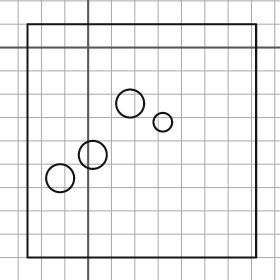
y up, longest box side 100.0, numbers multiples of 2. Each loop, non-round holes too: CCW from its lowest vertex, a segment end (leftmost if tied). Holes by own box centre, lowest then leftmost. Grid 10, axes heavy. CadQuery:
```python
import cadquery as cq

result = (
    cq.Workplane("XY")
    .moveTo(-26.0, -90.0)
    .lineTo(72.0, -90.0)
    .lineTo(72.0, 10.0)
    .lineTo(-26.0, 10.0)
    .close()
    .moveTo(-12.0, -56.0)
    .circle(6.0)
    .moveTo(2.0, -46.0)
    .circle(6.0)
    .moveTo(32.0, -32.0)
    .circle(4.0)
    .moveTo(18.0, -24.0)
    .circle(6.0)
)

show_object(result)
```